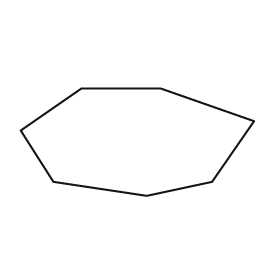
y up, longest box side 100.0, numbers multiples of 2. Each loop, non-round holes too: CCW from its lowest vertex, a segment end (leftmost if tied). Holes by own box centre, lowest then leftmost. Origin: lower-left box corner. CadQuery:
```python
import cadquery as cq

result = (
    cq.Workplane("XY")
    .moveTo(54.0, 0.0)
    .lineTo(82.0, 6.0)
    .lineTo(100.0, 32.0)
    .lineTo(60.0, 46.0)
    .lineTo(26.0, 46.0)
    .lineTo(0.0, 28.0)
    .lineTo(14.0, 6.0)
    .close()
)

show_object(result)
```